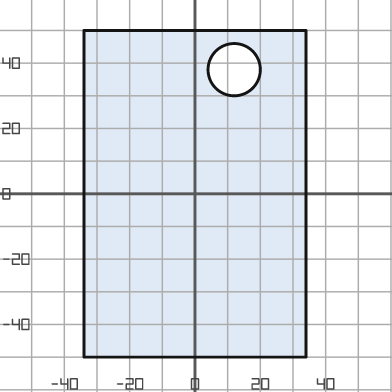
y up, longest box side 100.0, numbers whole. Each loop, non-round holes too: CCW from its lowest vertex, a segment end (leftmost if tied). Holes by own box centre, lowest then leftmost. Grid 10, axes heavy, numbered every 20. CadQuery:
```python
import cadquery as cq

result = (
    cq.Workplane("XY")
    .moveTo(-34.0, -50.0)
    .lineTo(34.0, -50.0)
    .lineTo(34.0, 50.0)
    .lineTo(-34.0, 50.0)
    .close()
    .moveTo(12.0, 38.0)
    .circle(8.0)
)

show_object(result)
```